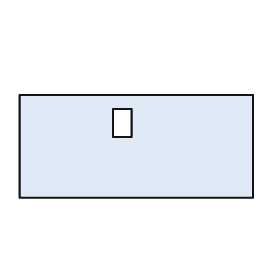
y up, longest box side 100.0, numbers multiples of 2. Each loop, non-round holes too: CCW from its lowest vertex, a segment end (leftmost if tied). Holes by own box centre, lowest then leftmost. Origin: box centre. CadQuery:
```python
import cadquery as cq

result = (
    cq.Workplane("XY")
    .moveTo(-50.0, -22.0)
    .lineTo(50.0, -22.0)
    .lineTo(50.0, 22.0)
    .lineTo(-50.0, 22.0)
    .close()
    .moveTo(-10.0, 4.0)
    .lineTo(-2.0, 4.0)
    .lineTo(-2.0, 16.0)
    .lineTo(-10.0, 16.0)
    .close()
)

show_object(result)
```